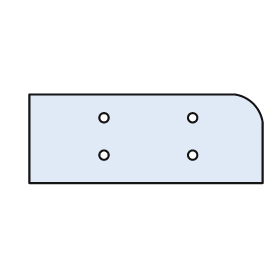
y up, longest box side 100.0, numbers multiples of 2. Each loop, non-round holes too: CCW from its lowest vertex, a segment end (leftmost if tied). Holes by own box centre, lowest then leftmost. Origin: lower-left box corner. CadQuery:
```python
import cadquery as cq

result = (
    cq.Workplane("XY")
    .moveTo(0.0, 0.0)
    .lineTo(100.0, 0.0)
    .lineTo(100.0, 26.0)
    .threePointArc((96.0, 34.0), (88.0, 38.0))
    .lineTo(0.0, 38.0)
    .close()
    .moveTo(32.0, 12.0)
    .circle(2.0)
    .moveTo(70.0, 12.0)
    .circle(2.0)
    .moveTo(32.0, 28.0)
    .circle(2.0)
    .moveTo(70.0, 28.0)
    .circle(2.0)
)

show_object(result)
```